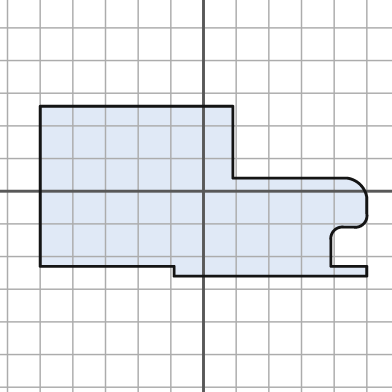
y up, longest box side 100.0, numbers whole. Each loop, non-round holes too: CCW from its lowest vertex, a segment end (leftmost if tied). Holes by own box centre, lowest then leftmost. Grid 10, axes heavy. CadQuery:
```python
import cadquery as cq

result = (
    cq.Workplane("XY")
    .moveTo(-9.0, -26.0)
    .lineTo(50.0, -26.0)
    .lineTo(50.0, -23.0)
    .lineTo(39.0, -23.0)
    .lineTo(39.0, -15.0)
    .threePointArc((40.0, -12.0), (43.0, -11.0))
    .lineTo(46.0, -11.0)
    .threePointArc((49.0, -10.0), (50.0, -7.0))
    .lineTo(50.0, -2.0)
    .threePointArc((48.0, 2.0), (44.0, 4.0))
    .lineTo(9.0, 4.0)
    .lineTo(9.0, 26.0)
    .lineTo(-50.0, 26.0)
    .lineTo(-50.0, -23.0)
    .lineTo(-9.0, -23.0)
    .close()
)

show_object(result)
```